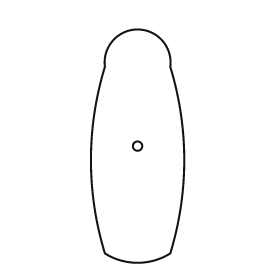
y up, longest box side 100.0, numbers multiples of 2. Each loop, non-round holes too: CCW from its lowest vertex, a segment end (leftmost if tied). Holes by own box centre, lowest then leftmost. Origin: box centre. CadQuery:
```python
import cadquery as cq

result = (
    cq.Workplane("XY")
    .moveTo(-14.0, -46.0)
    .threePointArc((0.0, -50.0), (14.0, -46.0))
    .threePointArc((20.0, -6.0), (14.0, 34.0))
    .threePointArc((0.0, 50.0), (-14.0, 34.0))
    .threePointArc((-20.0, -6.0), (-14.0, -46.0))
    .close()
    .moveTo(0.0, 0.0)
    .circle(2.0)
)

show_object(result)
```